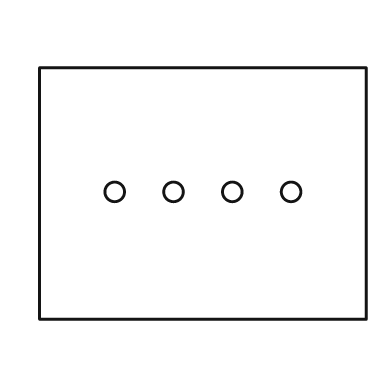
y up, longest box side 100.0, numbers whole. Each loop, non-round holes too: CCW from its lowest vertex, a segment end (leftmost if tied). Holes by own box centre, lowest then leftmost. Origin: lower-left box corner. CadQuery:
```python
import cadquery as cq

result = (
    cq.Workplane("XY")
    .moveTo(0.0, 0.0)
    .lineTo(100.0, 0.0)
    .lineTo(100.0, 77.0)
    .lineTo(0.0, 77.0)
    .close()
    .moveTo(23.0, 39.0)
    .circle(3.0)
    .moveTo(41.0, 39.0)
    .circle(3.0)
    .moveTo(59.0, 39.0)
    .circle(3.0)
    .moveTo(77.0, 39.0)
    .circle(3.0)
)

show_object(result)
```